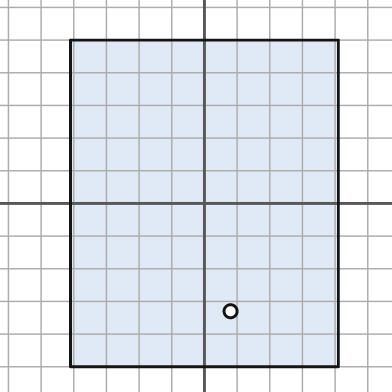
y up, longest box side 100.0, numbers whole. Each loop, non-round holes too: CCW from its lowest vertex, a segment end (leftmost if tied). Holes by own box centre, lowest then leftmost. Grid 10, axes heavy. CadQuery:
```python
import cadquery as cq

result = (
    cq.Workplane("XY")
    .moveTo(-41.0, -50.0)
    .lineTo(41.0, -50.0)
    .lineTo(41.0, 50.0)
    .lineTo(-41.0, 50.0)
    .close()
    .moveTo(8.0, -33.0)
    .circle(2.0)
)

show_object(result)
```